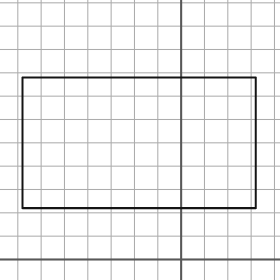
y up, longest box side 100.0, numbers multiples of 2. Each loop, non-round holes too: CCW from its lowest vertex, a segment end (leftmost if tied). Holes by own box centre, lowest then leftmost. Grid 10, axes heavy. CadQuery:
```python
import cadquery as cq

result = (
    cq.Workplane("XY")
    .moveTo(-68.0, 22.0)
    .lineTo(32.0, 22.0)
    .lineTo(32.0, 78.0)
    .lineTo(-68.0, 78.0)
    .close()
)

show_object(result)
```